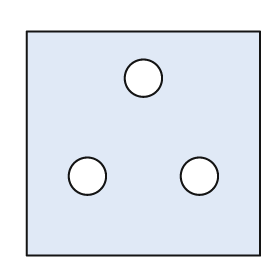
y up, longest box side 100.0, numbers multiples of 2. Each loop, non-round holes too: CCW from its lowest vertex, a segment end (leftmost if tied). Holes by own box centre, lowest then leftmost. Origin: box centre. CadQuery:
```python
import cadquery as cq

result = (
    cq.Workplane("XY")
    .moveTo(-50.0, -48.0)
    .lineTo(50.0, -48.0)
    .lineTo(50.0, 48.0)
    .lineTo(-50.0, 48.0)
    .close()
    .moveTo(-24.0, -14.0)
    .circle(8.0)
    .moveTo(24.0, -14.0)
    .circle(8.0)
    .moveTo(0.0, 28.0)
    .circle(8.0)
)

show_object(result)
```